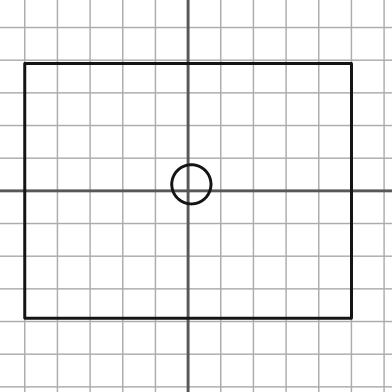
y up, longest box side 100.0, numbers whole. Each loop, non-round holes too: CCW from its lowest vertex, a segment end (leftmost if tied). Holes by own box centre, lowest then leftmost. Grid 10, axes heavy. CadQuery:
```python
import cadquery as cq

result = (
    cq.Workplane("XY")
    .moveTo(-50.0, -39.0)
    .lineTo(50.0, -39.0)
    .lineTo(50.0, 39.0)
    .lineTo(-50.0, 39.0)
    .close()
    .moveTo(1.0, 2.0)
    .circle(6.0)
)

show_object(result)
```